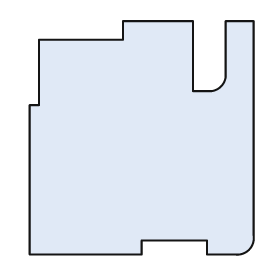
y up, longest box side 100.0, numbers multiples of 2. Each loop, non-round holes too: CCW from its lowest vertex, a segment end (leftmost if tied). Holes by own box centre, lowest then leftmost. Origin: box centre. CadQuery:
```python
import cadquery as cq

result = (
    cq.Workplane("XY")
    .moveTo(-48.0, -50.0)
    .lineTo(0.0, -50.0)
    .lineTo(0.0, -44.0)
    .lineTo(28.0, -44.0)
    .lineTo(28.0, -50.0)
    .lineTo(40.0, -50.0)
    .threePointArc((46.0, -48.0), (48.0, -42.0))
    .lineTo(48.0, 50.0)
    .lineTo(36.0, 50.0)
    .lineTo(36.0, 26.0)
    .threePointArc((34.0, 22.0), (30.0, 20.0))
    .lineTo(22.0, 20.0)
    .lineTo(22.0, 50.0)
    .lineTo(-8.0, 50.0)
    .lineTo(-8.0, 42.0)
    .lineTo(-44.0, 42.0)
    .lineTo(-44.0, 14.0)
    .lineTo(-48.0, 14.0)
    .close()
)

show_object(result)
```